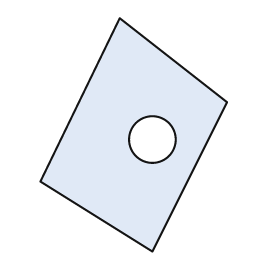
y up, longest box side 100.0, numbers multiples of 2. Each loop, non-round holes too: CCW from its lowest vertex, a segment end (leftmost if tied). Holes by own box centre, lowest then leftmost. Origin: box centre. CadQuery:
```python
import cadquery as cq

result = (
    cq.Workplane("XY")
    .moveTo(8.0, -50.0)
    .lineTo(40.0, 14.0)
    .lineTo(-6.0, 50.0)
    .lineTo(-40.0, -20.0)
    .close()
    .moveTo(8.0, -2.0)
    .circle(10.0)
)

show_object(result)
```